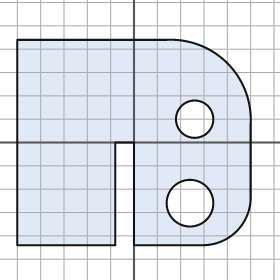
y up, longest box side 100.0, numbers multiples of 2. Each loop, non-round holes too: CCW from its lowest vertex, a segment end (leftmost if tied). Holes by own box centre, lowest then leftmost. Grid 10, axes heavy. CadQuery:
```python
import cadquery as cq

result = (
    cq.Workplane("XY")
    .moveTo(-50.0, -44.0)
    .lineTo(-8.0, -44.0)
    .lineTo(-8.0, 0.0)
    .lineTo(0.0, 0.0)
    .lineTo(0.0, -44.0)
    .lineTo(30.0, -44.0)
    .threePointArc((44.0, -38.0), (50.0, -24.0))
    .lineTo(50.0, 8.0)
    .threePointArc((40.0, 34.0), (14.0, 44.0))
    .lineTo(-50.0, 44.0)
    .close()
    .moveTo(24.0, -26.0)
    .circle(10.0)
    .moveTo(26.0, 10.0)
    .circle(8.0)
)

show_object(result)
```